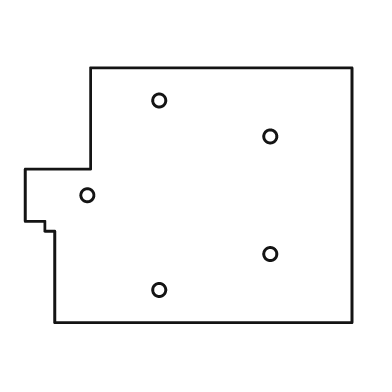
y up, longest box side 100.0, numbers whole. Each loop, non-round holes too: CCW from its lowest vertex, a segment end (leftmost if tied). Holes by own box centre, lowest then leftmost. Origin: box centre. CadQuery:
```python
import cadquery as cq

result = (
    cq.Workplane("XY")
    .moveTo(-41.0, -39.0)
    .lineTo(50.0, -39.0)
    .lineTo(50.0, 39.0)
    .lineTo(-30.0, 39.0)
    .lineTo(-30.0, 8.0)
    .lineTo(-50.0, 8.0)
    .lineTo(-50.0, -8.0)
    .lineTo(-44.0, -8.0)
    .lineTo(-44.0, -11.0)
    .lineTo(-41.0, -11.0)
    .close()
    .moveTo(-9.0, -29.0)
    .circle(2.0)
    .moveTo(25.0, -18.0)
    .circle(2.0)
    .moveTo(-31.0, 0.0)
    .circle(2.0)
    .moveTo(25.0, 18.0)
    .circle(2.0)
    .moveTo(-9.0, 29.0)
    .circle(2.0)
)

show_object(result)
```